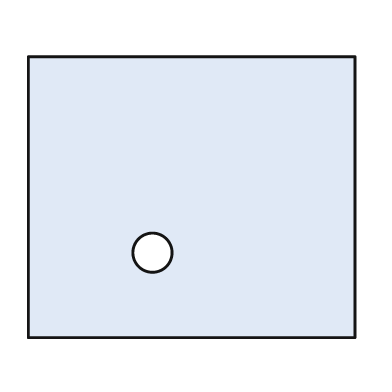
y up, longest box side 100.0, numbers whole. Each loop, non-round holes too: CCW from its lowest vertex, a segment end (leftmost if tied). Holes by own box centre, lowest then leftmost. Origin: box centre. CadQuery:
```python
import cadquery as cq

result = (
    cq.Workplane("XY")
    .moveTo(-50.0, -43.0)
    .lineTo(50.0, -43.0)
    .lineTo(50.0, 43.0)
    .lineTo(-50.0, 43.0)
    .close()
    .moveTo(-12.0, -17.0)
    .circle(6.0)
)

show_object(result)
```